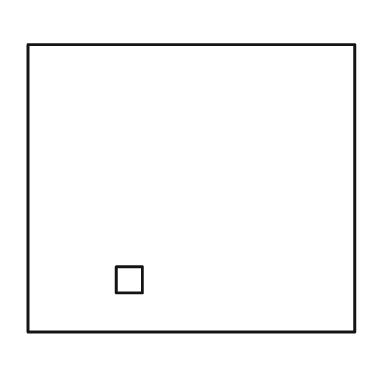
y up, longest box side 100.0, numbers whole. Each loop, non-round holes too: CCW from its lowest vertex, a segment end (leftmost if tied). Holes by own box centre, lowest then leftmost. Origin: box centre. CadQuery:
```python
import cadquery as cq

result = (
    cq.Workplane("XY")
    .moveTo(-50.0, -44.0)
    .lineTo(50.0, -44.0)
    .lineTo(50.0, 44.0)
    .lineTo(-50.0, 44.0)
    .close()
    .moveTo(-23.0, -32.0)
    .lineTo(-15.0, -32.0)
    .lineTo(-15.0, -24.0)
    .lineTo(-23.0, -24.0)
    .close()
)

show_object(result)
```